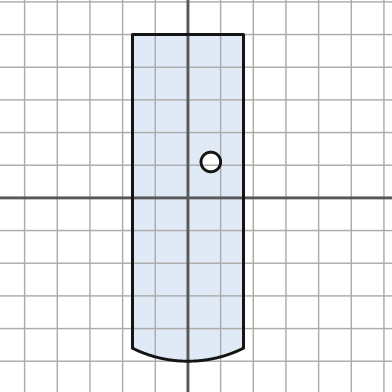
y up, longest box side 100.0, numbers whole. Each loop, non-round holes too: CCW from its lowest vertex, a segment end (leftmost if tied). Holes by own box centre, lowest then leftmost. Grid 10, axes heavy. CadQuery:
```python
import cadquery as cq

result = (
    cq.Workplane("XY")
    .moveTo(-17.0, -46.0)
    .threePointArc((0.0, -50.0), (17.0, -46.0))
    .lineTo(17.0, 50.0)
    .lineTo(-17.0, 50.0)
    .close()
    .moveTo(7.0, 11.0)
    .circle(3.0)
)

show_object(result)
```